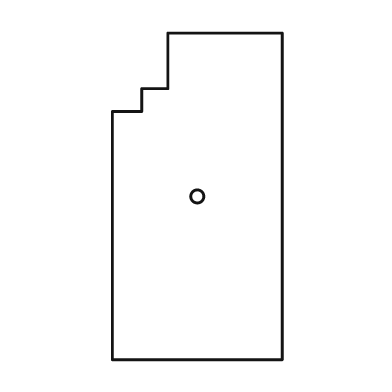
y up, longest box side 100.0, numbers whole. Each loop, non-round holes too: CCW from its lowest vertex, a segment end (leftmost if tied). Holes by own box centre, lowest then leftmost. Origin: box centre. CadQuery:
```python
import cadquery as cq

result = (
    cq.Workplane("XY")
    .moveTo(-26.0, -50.0)
    .lineTo(26.0, -50.0)
    .lineTo(26.0, 50.0)
    .lineTo(-9.0, 50.0)
    .lineTo(-9.0, 33.0)
    .lineTo(-17.0, 33.0)
    .lineTo(-17.0, 26.0)
    .lineTo(-26.0, 26.0)
    .close()
    .moveTo(0.0, 0.0)
    .circle(2.0)
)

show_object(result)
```